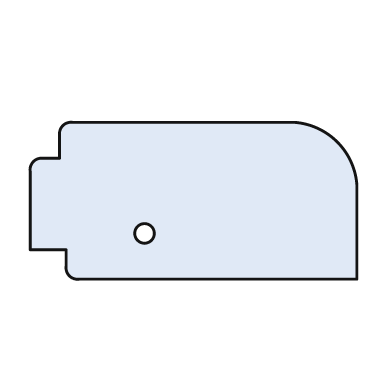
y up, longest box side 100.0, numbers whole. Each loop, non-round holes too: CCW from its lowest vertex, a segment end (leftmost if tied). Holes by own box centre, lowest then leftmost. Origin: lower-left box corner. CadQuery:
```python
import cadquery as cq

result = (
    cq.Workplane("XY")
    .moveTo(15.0, 0.0)
    .lineTo(100.0, 0.0)
    .lineTo(100.0, 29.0)
    .threePointArc((94.0, 42.0), (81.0, 48.0))
    .lineTo(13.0, 48.0)
    .threePointArc((10.0, 47.0), (9.0, 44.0))
    .lineTo(9.0, 37.0)
    .lineTo(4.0, 37.0)
    .threePointArc((1.0, 36.0), (0.0, 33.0))
    .lineTo(0.0, 9.0)
    .lineTo(11.0, 9.0)
    .lineTo(11.0, 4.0)
    .threePointArc((12.0, 1.0), (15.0, 0.0))
    .close()
    .moveTo(35.0, 14.0)
    .circle(3.0)
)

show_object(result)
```